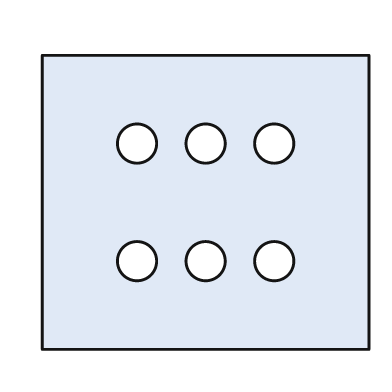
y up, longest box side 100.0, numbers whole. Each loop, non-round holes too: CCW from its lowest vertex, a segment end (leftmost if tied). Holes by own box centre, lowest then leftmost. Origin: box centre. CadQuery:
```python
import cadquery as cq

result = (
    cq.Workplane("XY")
    .moveTo(-50.0, -45.0)
    .lineTo(50.0, -45.0)
    .lineTo(50.0, 45.0)
    .lineTo(-50.0, 45.0)
    .close()
    .moveTo(-21.0, -18.0)
    .circle(6.0)
    .moveTo(0.0, -18.0)
    .circle(6.0)
    .moveTo(21.0, -18.0)
    .circle(6.0)
    .moveTo(-21.0, 18.0)
    .circle(6.0)
    .moveTo(0.0, 18.0)
    .circle(6.0)
    .moveTo(21.0, 18.0)
    .circle(6.0)
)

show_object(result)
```